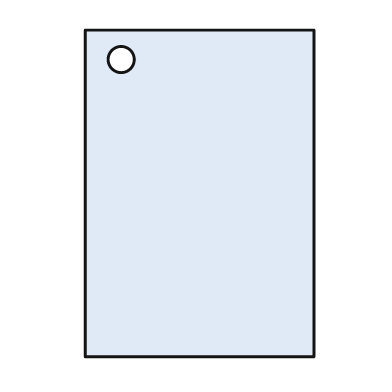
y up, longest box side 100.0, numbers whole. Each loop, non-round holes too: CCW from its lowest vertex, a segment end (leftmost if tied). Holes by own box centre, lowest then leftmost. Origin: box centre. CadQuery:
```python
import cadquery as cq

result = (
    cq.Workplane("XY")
    .moveTo(-35.0, -50.0)
    .lineTo(35.0, -50.0)
    .lineTo(35.0, 50.0)
    .lineTo(-35.0, 50.0)
    .close()
    .moveTo(-24.0, 41.0)
    .circle(4.0)
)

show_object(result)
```